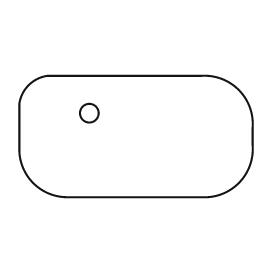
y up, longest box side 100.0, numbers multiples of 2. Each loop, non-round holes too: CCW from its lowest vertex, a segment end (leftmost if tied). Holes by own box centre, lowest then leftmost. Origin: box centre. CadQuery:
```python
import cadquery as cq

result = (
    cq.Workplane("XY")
    .moveTo(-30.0, -26.0)
    .lineTo(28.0, -26.0)
    .threePointArc((44.0, -20.0), (50.0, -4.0))
    .lineTo(50.0, 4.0)
    .threePointArc((44.0, 20.0), (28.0, 26.0))
    .lineTo(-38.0, 26.0)
    .threePointArc((-46.0, 22.0), (-50.0, 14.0))
    .lineTo(-50.0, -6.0)
    .threePointArc((-44.0, -20.0), (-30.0, -26.0))
    .close()
    .moveTo(-20.0, 10.0)
    .circle(4.0)
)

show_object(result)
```